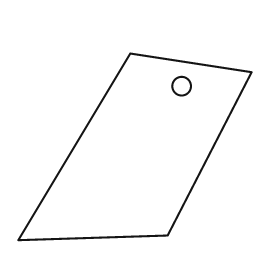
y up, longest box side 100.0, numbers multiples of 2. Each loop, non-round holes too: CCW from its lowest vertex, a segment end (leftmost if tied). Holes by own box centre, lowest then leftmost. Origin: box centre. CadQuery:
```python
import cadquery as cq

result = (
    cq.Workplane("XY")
    .moveTo(-50.0, -40.0)
    .lineTo(14.0, -38.0)
    .lineTo(50.0, 32.0)
    .lineTo(-2.0, 40.0)
    .close()
    .moveTo(20.0, 26.0)
    .circle(4.0)
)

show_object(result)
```